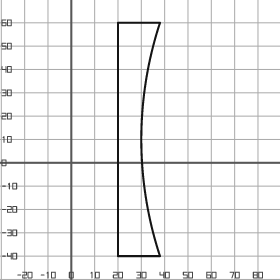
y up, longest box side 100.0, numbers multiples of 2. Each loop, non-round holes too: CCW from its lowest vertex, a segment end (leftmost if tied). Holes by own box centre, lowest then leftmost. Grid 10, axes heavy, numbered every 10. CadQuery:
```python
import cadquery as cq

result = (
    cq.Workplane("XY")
    .moveTo(20.0, -40.0)
    .lineTo(38.0, -40.0)
    .threePointArc((30.0, 10.0), (38.0, 60.0))
    .lineTo(20.0, 60.0)
    .close()
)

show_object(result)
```